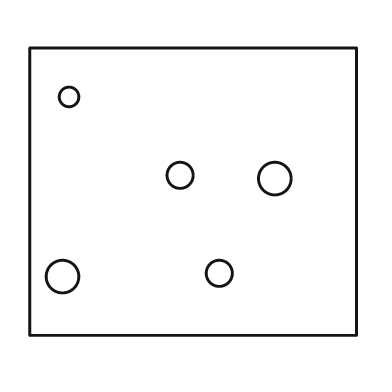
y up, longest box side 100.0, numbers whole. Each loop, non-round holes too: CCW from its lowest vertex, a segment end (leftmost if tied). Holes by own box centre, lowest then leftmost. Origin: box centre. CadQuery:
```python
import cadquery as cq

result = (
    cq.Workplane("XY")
    .moveTo(-50.0, -44.0)
    .lineTo(50.0, -44.0)
    .lineTo(50.0, 44.0)
    .lineTo(-50.0, 44.0)
    .close()
    .moveTo(-40.0, -26.0)
    .circle(5.0)
    .moveTo(8.0, -25.0)
    .circle(4.0)
    .moveTo(25.0, 4.0)
    .circle(5.0)
    .moveTo(-4.0, 5.0)
    .circle(4.0)
    .moveTo(-38.0, 29.0)
    .circle(3.0)
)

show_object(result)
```